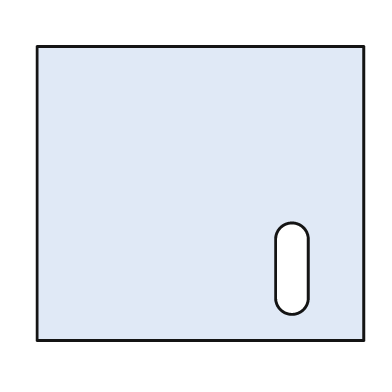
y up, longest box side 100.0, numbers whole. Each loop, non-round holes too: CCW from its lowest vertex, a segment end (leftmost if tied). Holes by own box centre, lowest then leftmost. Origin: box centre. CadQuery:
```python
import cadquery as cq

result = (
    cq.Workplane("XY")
    .moveTo(-50.0, -45.0)
    .lineTo(50.0, -45.0)
    .lineTo(50.0, 45.0)
    .lineTo(-50.0, 45.0)
    .close()
    .moveTo(23.0, -32.0)
    .threePointArc((28.0, -37.0), (33.0, -32.0))
    .lineTo(33.0, -14.0)
    .threePointArc((28.0, -9.0), (23.0, -14.0))
    .close()
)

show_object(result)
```